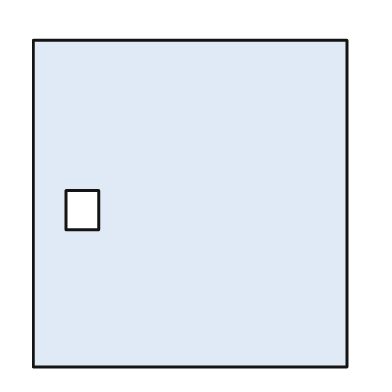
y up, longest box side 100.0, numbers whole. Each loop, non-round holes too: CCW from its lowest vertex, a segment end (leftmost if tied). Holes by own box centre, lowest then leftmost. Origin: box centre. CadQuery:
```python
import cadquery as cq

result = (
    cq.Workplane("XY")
    .moveTo(-48.0, -50.0)
    .lineTo(48.0, -50.0)
    .lineTo(48.0, 50.0)
    .lineTo(-48.0, 50.0)
    .close()
    .moveTo(-38.0, -8.0)
    .lineTo(-28.0, -8.0)
    .lineTo(-28.0, 4.0)
    .lineTo(-38.0, 4.0)
    .close()
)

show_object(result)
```